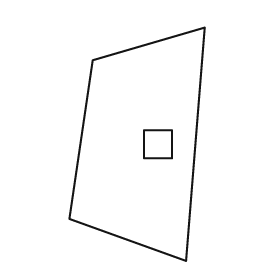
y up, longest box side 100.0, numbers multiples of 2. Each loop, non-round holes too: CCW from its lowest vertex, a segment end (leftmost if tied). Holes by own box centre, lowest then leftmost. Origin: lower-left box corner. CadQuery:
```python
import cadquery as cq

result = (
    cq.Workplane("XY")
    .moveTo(50.0, 0.0)
    .lineTo(58.0, 100.0)
    .lineTo(10.0, 86.0)
    .lineTo(0.0, 18.0)
    .close()
    .moveTo(32.0, 44.0)
    .lineTo(44.0, 44.0)
    .lineTo(44.0, 56.0)
    .lineTo(32.0, 56.0)
    .close()
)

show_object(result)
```